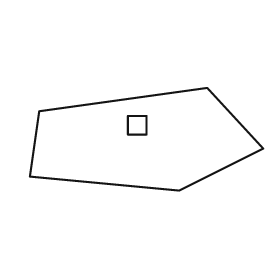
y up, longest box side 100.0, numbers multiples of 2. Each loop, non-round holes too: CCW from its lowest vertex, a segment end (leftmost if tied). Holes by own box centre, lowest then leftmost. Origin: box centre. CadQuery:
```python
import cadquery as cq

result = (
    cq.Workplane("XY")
    .moveTo(14.0, -22.0)
    .lineTo(50.0, -4.0)
    .lineTo(26.0, 22.0)
    .lineTo(-46.0, 12.0)
    .lineTo(-50.0, -16.0)
    .close()
    .moveTo(-8.0, 2.0)
    .lineTo(0.0, 2.0)
    .lineTo(0.0, 10.0)
    .lineTo(-8.0, 10.0)
    .close()
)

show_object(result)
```